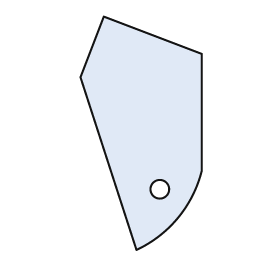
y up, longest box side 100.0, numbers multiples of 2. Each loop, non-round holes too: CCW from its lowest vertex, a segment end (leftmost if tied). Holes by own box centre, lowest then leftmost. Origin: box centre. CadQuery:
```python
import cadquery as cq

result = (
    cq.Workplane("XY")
    .moveTo(-2.0, -50.0)
    .threePointArc((16.0, -36.0), (26.0, -16.0))
    .lineTo(26.0, 34.0)
    .lineTo(-16.0, 50.0)
    .lineTo(-26.0, 24.0)
    .close()
    .moveTo(8.0, -24.0)
    .circle(4.0)
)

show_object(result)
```